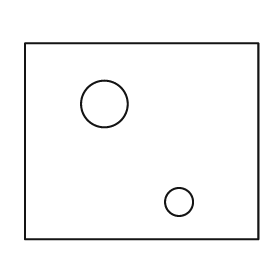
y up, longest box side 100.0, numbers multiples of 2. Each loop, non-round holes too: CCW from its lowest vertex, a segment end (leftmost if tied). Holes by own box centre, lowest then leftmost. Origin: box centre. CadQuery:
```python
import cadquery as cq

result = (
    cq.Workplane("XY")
    .moveTo(-50.0, -42.0)
    .lineTo(50.0, -42.0)
    .lineTo(50.0, 42.0)
    .lineTo(-50.0, 42.0)
    .close()
    .moveTo(16.0, -26.0)
    .circle(6.0)
    .moveTo(-16.0, 16.0)
    .circle(10.0)
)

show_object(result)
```